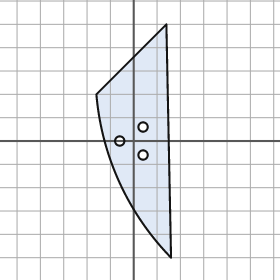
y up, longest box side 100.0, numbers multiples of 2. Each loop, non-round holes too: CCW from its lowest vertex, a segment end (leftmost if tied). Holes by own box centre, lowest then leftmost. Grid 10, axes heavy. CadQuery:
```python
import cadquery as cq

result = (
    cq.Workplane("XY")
    .moveTo(16.0, -50.0)
    .lineTo(14.0, 50.0)
    .lineTo(-16.0, 20.0)
    .threePointArc((-6.0, -18.0), (16.0, -50.0))
    .close()
    .moveTo(4.0, -6.0)
    .circle(2.0)
    .moveTo(-6.0, 0.0)
    .circle(2.0)
    .moveTo(4.0, 6.0)
    .circle(2.0)
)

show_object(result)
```